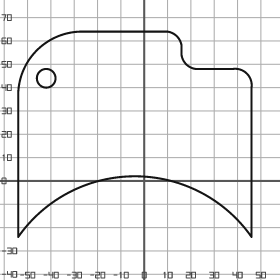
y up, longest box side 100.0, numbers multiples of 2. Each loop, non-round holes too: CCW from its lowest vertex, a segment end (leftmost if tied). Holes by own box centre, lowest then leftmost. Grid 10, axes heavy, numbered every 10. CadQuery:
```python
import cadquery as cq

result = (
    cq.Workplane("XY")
    .moveTo(-54.0, -24.0)
    .threePointArc((-4.0, 2.0), (46.0, -24.0))
    .lineTo(46.0, 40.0)
    .threePointArc((44.0, 46.0), (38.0, 48.0))
    .lineTo(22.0, 48.0)
    .threePointArc((18.0, 50.0), (16.0, 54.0))
    .lineTo(16.0, 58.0)
    .threePointArc((14.0, 62.0), (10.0, 64.0))
    .lineTo(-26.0, 64.0)
    .threePointArc((-46.0, 56.0), (-54.0, 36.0))
    .close()
    .moveTo(-42.0, 44.0)
    .circle(4.0)
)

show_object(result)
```